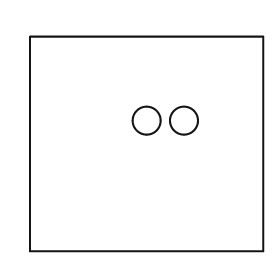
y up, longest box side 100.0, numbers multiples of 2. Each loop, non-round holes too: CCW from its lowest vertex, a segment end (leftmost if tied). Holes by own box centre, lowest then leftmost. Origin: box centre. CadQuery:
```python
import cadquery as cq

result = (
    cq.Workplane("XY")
    .moveTo(-50.0, -46.0)
    .lineTo(50.0, -46.0)
    .lineTo(50.0, 46.0)
    .lineTo(-50.0, 46.0)
    .close()
    .moveTo(0.0, 10.0)
    .circle(6.0)
    .moveTo(16.0, 10.0)
    .circle(6.0)
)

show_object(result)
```